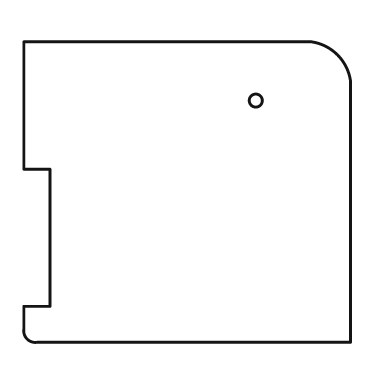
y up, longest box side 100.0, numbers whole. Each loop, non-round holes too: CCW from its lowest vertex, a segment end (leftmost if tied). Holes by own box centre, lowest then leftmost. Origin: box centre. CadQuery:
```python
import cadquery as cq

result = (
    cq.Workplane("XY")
    .moveTo(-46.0, -46.0)
    .lineTo(50.0, -46.0)
    .lineTo(50.0, 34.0)
    .threePointArc((46.0, 42.0), (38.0, 46.0))
    .lineTo(-50.0, 46.0)
    .lineTo(-50.0, 7.0)
    .lineTo(-42.0, 7.0)
    .lineTo(-42.0, -35.0)
    .lineTo(-50.0, -35.0)
    .lineTo(-50.0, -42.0)
    .threePointArc((-49.0, -45.0), (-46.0, -46.0))
    .close()
    .moveTo(21.0, 28.0)
    .circle(2.0)
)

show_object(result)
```